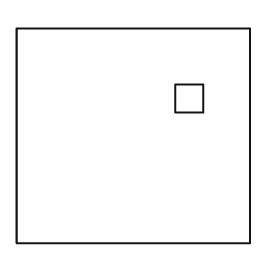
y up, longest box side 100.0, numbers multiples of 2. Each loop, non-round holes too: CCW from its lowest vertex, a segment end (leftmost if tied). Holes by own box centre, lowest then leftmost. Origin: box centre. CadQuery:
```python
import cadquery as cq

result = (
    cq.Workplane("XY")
    .moveTo(-50.0, -46.0)
    .lineTo(50.0, -46.0)
    .lineTo(50.0, 46.0)
    .lineTo(-50.0, 46.0)
    .close()
    .moveTo(18.0, 10.0)
    .lineTo(30.0, 10.0)
    .lineTo(30.0, 22.0)
    .lineTo(18.0, 22.0)
    .close()
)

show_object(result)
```